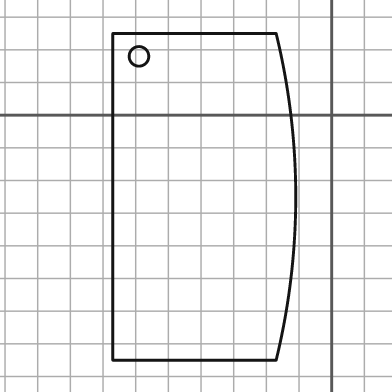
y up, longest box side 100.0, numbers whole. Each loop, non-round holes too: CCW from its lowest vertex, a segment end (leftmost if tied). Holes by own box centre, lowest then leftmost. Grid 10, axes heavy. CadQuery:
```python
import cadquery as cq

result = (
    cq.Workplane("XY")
    .moveTo(-67.0, -75.0)
    .lineTo(-17.0, -75.0)
    .threePointArc((-11.0, -25.0), (-17.0, 25.0))
    .lineTo(-67.0, 25.0)
    .close()
    .moveTo(-59.0, 18.0)
    .circle(3.0)
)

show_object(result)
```